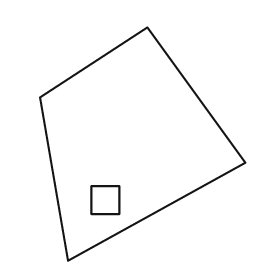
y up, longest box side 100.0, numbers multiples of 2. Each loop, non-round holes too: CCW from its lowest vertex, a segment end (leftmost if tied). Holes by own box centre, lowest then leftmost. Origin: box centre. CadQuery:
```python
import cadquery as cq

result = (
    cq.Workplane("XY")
    .moveTo(-32.0, -50.0)
    .lineTo(44.0, -8.0)
    .lineTo(2.0, 50.0)
    .lineTo(-44.0, 20.0)
    .close()
    .moveTo(-22.0, -30.0)
    .lineTo(-10.0, -30.0)
    .lineTo(-10.0, -18.0)
    .lineTo(-22.0, -18.0)
    .close()
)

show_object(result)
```